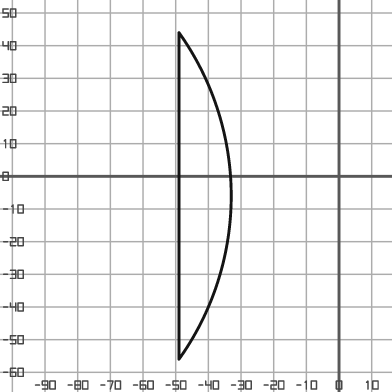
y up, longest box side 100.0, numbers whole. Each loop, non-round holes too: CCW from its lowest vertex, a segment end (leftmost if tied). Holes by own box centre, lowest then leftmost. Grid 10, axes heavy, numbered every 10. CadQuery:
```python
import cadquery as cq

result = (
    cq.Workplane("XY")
    .moveTo(-49.0, -56.0)
    .threePointArc((-33.0, -6.0), (-49.0, 44.0))
    .close()
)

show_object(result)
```